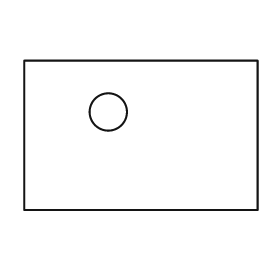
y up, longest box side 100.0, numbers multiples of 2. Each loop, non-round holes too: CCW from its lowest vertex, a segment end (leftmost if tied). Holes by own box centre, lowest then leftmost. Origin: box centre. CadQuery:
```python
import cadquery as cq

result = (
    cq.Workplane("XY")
    .moveTo(-50.0, -32.0)
    .lineTo(50.0, -32.0)
    .lineTo(50.0, 32.0)
    .lineTo(-50.0, 32.0)
    .close()
    .moveTo(-14.0, 10.0)
    .circle(8.0)
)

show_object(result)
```